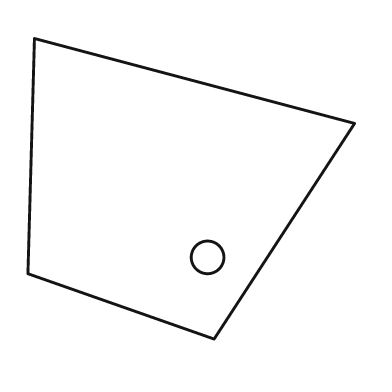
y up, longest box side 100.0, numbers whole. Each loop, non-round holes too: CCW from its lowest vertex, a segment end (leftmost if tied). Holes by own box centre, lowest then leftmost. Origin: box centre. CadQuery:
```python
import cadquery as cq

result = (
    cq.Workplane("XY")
    .moveTo(7.0, -46.0)
    .lineTo(50.0, 20.0)
    .lineTo(-48.0, 46.0)
    .lineTo(-50.0, -26.0)
    .close()
    .moveTo(5.0, -21.0)
    .circle(5.0)
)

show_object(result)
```